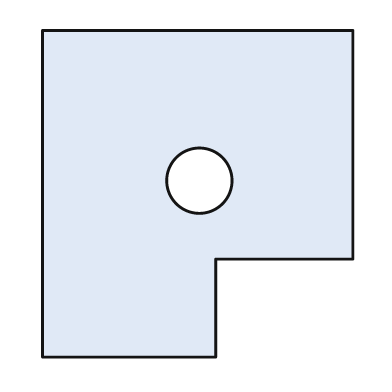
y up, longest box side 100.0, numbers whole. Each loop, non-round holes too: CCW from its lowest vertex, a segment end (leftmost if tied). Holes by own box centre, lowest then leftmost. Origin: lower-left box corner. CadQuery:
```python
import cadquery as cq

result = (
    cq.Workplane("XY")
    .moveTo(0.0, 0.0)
    .lineTo(53.0, 0.0)
    .lineTo(53.0, 30.0)
    .lineTo(95.0, 30.0)
    .lineTo(95.0, 100.0)
    .lineTo(0.0, 100.0)
    .close()
    .moveTo(48.0, 54.0)
    .circle(10.0)
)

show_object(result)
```